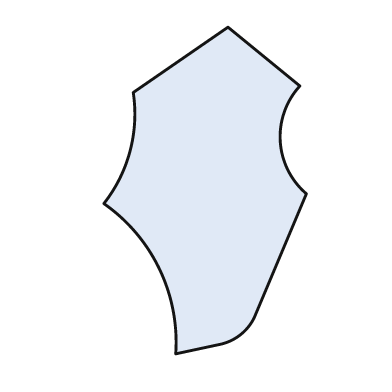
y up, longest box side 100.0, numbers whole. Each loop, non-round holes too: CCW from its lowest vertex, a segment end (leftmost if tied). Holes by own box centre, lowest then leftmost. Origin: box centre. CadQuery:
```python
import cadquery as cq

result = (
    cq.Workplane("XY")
    .moveTo(-9.0, -50.0)
    .lineTo(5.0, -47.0)
    .threePointArc((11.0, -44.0), (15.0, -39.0))
    .lineTo(31.0, -1.0)
    .threePointArc((23.0, 15.0), (29.0, 32.0))
    .lineTo(7.0, 50.0)
    .lineTo(-22.0, 30.0)
    .threePointArc((-23.0, 12.0), (-31.0, -4.0))
    .threePointArc((-14.0, -24.0), (-9.0, -50.0))
    .close()
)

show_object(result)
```